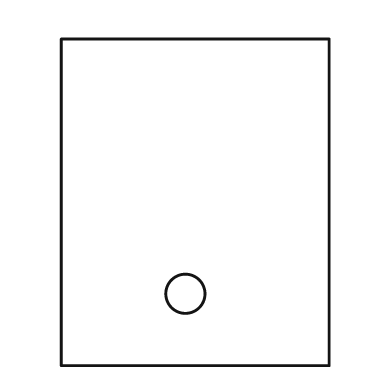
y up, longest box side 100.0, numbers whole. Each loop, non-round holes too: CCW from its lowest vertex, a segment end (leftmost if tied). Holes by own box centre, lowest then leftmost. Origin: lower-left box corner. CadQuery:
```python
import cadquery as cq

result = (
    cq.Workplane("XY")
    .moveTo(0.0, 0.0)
    .lineTo(82.0, 0.0)
    .lineTo(82.0, 100.0)
    .lineTo(0.0, 100.0)
    .close()
    .moveTo(38.0, 22.0)
    .circle(6.0)
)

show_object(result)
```